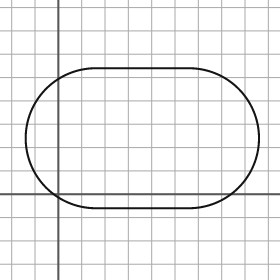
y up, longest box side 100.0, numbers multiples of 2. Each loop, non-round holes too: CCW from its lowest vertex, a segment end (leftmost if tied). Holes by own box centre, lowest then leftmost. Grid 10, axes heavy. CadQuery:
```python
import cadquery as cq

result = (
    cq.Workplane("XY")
    .moveTo(16.0, -6.0)
    .lineTo(56.0, -6.0)
    .threePointArc((86.0, 24.0), (56.0, 54.0))
    .lineTo(16.0, 54.0)
    .threePointArc((-14.0, 24.0), (16.0, -6.0))
    .close()
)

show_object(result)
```